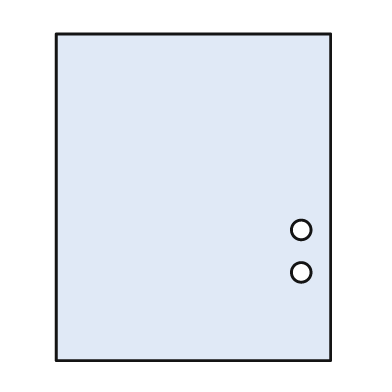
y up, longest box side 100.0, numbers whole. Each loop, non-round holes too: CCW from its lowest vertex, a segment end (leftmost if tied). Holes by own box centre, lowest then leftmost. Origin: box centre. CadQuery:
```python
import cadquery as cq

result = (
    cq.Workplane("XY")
    .moveTo(-42.0, -50.0)
    .lineTo(42.0, -50.0)
    .lineTo(42.0, 50.0)
    .lineTo(-42.0, 50.0)
    .close()
    .moveTo(33.0, -23.0)
    .circle(3.0)
    .moveTo(33.0, -10.0)
    .circle(3.0)
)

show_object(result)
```